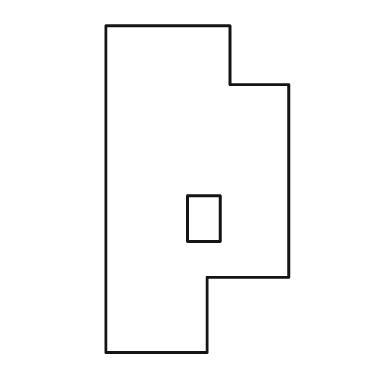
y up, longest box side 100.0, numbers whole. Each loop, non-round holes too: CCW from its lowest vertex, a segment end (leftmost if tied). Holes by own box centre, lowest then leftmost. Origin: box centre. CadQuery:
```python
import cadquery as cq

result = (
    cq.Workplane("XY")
    .moveTo(-28.0, -50.0)
    .lineTo(3.0, -50.0)
    .lineTo(3.0, -27.0)
    .lineTo(28.0, -27.0)
    .lineTo(28.0, 32.0)
    .lineTo(10.0, 32.0)
    .lineTo(10.0, 50.0)
    .lineTo(-28.0, 50.0)
    .close()
    .moveTo(-3.0, -16.0)
    .lineTo(7.0, -16.0)
    .lineTo(7.0, -2.0)
    .lineTo(-3.0, -2.0)
    .close()
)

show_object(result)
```